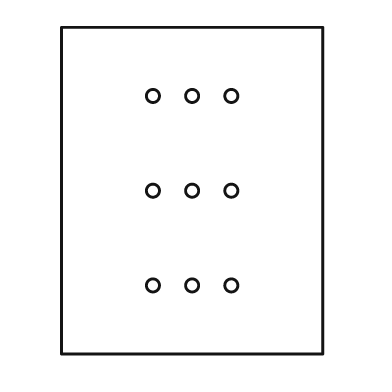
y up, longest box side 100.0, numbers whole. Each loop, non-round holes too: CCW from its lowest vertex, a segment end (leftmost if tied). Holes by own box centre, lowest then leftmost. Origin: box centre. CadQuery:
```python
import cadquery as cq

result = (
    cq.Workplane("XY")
    .moveTo(-40.0, -50.0)
    .lineTo(40.0, -50.0)
    .lineTo(40.0, 50.0)
    .lineTo(-40.0, 50.0)
    .close()
    .moveTo(-12.0, -29.0)
    .circle(2.0)
    .moveTo(0.0, -29.0)
    .circle(2.0)
    .moveTo(12.0, -29.0)
    .circle(2.0)
    .moveTo(-12.0, 0.0)
    .circle(2.0)
    .moveTo(0.0, 0.0)
    .circle(2.0)
    .moveTo(12.0, 0.0)
    .circle(2.0)
    .moveTo(-12.0, 29.0)
    .circle(2.0)
    .moveTo(0.0, 29.0)
    .circle(2.0)
    .moveTo(12.0, 29.0)
    .circle(2.0)
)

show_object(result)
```